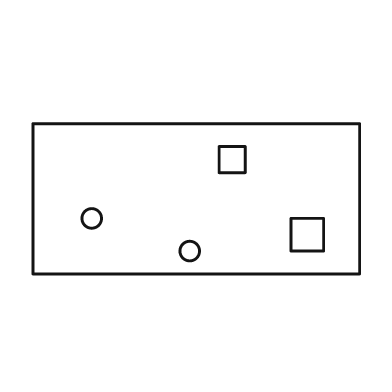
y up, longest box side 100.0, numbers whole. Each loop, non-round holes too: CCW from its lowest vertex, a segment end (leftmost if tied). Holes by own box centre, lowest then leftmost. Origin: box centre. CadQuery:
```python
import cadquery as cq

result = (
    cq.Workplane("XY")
    .moveTo(-50.0, -23.0)
    .lineTo(50.0, -23.0)
    .lineTo(50.0, 23.0)
    .lineTo(-50.0, 23.0)
    .close()
    .moveTo(-2.0, -16.0)
    .circle(3.0)
    .moveTo(29.0, -16.0)
    .lineTo(39.0, -16.0)
    .lineTo(39.0, -6.0)
    .lineTo(29.0, -6.0)
    .close()
    .moveTo(-32.0, -6.0)
    .circle(3.0)
    .moveTo(7.0, 8.0)
    .lineTo(15.0, 8.0)
    .lineTo(15.0, 16.0)
    .lineTo(7.0, 16.0)
    .close()
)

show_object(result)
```